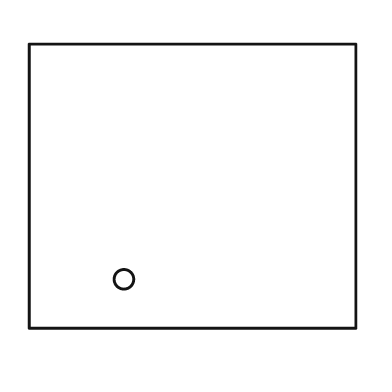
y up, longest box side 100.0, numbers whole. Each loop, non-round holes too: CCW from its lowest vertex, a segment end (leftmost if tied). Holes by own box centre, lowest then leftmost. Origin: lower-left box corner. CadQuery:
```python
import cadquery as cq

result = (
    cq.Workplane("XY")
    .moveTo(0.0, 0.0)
    .lineTo(100.0, 0.0)
    .lineTo(100.0, 87.0)
    .lineTo(0.0, 87.0)
    .close()
    .moveTo(29.0, 15.0)
    .circle(3.0)
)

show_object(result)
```